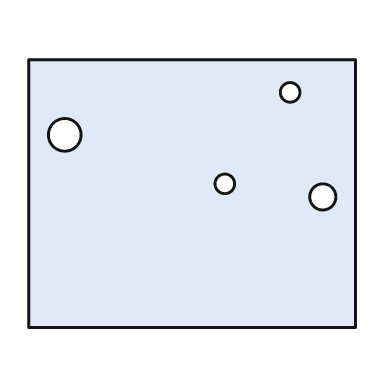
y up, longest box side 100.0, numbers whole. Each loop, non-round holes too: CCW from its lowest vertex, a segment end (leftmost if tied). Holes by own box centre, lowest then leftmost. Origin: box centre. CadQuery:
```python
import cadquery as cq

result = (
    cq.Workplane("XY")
    .moveTo(-50.0, -41.0)
    .lineTo(50.0, -41.0)
    .lineTo(50.0, 41.0)
    .lineTo(-50.0, 41.0)
    .close()
    .moveTo(40.0, -1.0)
    .circle(4.0)
    .moveTo(10.0, 3.0)
    .circle(3.0)
    .moveTo(-39.0, 18.0)
    .circle(5.0)
    .moveTo(30.0, 31.0)
    .circle(3.0)
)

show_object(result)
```